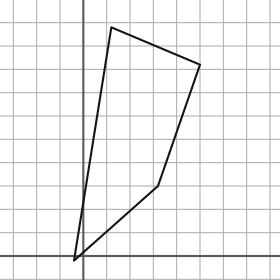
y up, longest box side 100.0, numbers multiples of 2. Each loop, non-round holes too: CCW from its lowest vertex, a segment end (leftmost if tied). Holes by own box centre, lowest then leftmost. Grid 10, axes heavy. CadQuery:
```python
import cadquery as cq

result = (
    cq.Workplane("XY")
    .moveTo(-4.0, -2.0)
    .lineTo(32.0, 30.0)
    .lineTo(50.0, 82.0)
    .lineTo(12.0, 98.0)
    .close()
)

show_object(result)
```